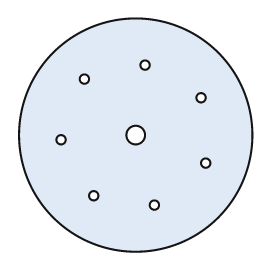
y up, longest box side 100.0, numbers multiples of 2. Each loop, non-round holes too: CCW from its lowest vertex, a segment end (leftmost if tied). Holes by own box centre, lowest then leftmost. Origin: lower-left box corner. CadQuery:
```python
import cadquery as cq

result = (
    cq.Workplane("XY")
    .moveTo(50.0, 50.0)
    .circle(50.0)
    .moveTo(58.0, 20.0)
    .circle(2.0)
    .moveTo(32.0, 24.0)
    .circle(2.0)
    .moveTo(80.0, 38.0)
    .circle(2.0)
    .moveTo(18.0, 48.0)
    .circle(2.0)
    .moveTo(50.0, 50.0)
    .circle(4.0)
    .moveTo(78.0, 66.0)
    .circle(2.0)
    .moveTo(28.0, 74.0)
    .circle(2.0)
    .moveTo(54.0, 80.0)
    .circle(2.0)
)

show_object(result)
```